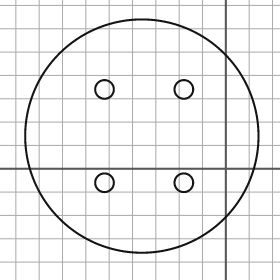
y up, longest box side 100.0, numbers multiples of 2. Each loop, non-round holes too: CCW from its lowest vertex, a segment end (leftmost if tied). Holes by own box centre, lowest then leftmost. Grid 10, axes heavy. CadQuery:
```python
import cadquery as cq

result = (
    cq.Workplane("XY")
    .moveTo(-36.0, 14.0)
    .circle(50.0)
    .moveTo(-52.0, -6.0)
    .circle(4.0)
    .moveTo(-18.0, -6.0)
    .circle(4.0)
    .moveTo(-52.0, 34.0)
    .circle(4.0)
    .moveTo(-18.0, 34.0)
    .circle(4.0)
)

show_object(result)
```